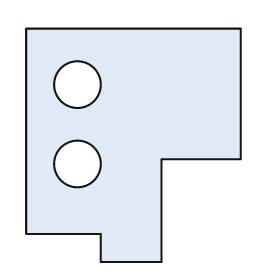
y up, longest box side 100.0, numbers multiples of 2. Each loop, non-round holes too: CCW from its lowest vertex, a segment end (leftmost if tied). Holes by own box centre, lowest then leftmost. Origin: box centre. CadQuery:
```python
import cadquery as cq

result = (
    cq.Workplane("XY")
    .moveTo(-14.0, -50.0)
    .lineTo(12.0, -50.0)
    .lineTo(12.0, -6.0)
    .lineTo(46.0, -6.0)
    .lineTo(46.0, 50.0)
    .lineTo(-46.0, 50.0)
    .lineTo(-46.0, -38.0)
    .lineTo(-14.0, -38.0)
    .close()
    .moveTo(-24.0, -8.0)
    .circle(10.0)
    .moveTo(-24.0, 26.0)
    .circle(10.0)
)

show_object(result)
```